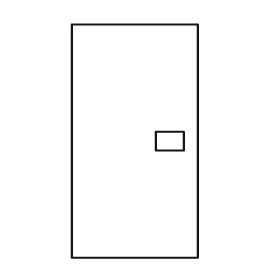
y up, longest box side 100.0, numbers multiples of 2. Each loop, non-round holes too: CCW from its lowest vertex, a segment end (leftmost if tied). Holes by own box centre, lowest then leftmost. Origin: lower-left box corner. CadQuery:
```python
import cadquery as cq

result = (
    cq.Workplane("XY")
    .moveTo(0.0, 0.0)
    .lineTo(54.0, 0.0)
    .lineTo(54.0, 100.0)
    .lineTo(0.0, 100.0)
    .close()
    .moveTo(36.0, 46.0)
    .lineTo(48.0, 46.0)
    .lineTo(48.0, 54.0)
    .lineTo(36.0, 54.0)
    .close()
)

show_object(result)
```